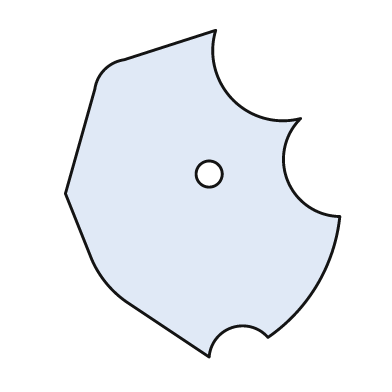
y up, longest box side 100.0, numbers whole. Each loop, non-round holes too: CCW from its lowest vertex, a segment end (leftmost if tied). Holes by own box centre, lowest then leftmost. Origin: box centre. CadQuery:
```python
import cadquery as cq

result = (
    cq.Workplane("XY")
    .moveTo(2.0, -50.0)
    .threePointArc((9.0, -41.0), (20.0, -44.0))
    .threePointArc((35.0, -28.0), (42.0, -7.0))
    .threePointArc((26.0, 4.0), (30.0, 23.0))
    .threePointArc((9.0, 29.0), (4.0, 50.0))
    .lineTo(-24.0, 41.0)
    .threePointArc((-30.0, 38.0), (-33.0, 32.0))
    .lineTo(-42.0, 0.0)
    .lineTo(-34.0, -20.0)
    .threePointArc((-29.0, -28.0), (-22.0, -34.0))
    .close()
    .moveTo(2.0, 6.0)
    .circle(4.0)
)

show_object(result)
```